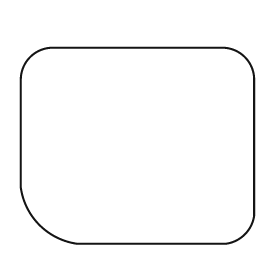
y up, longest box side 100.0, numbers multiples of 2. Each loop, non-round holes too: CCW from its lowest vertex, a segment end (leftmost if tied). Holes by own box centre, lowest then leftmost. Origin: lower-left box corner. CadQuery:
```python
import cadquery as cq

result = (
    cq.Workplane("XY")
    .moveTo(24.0, 0.0)
    .lineTo(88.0, 0.0)
    .threePointArc((96.0, 4.0), (100.0, 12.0))
    .lineTo(100.0, 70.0)
    .threePointArc((96.0, 80.0), (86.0, 84.0))
    .lineTo(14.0, 84.0)
    .threePointArc((4.0, 80.0), (0.0, 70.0))
    .lineTo(0.0, 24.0)
    .threePointArc((8.0, 8.0), (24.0, 0.0))
    .close()
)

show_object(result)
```